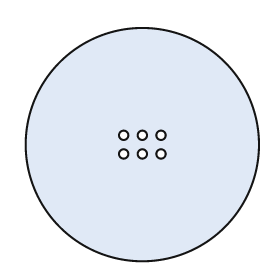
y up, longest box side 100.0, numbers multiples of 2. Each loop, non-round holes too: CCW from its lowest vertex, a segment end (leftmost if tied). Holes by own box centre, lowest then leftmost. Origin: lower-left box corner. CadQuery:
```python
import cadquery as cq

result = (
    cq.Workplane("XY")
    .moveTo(50.0, 50.0)
    .circle(50.0)
    .moveTo(42.0, 46.0)
    .circle(2.0)
    .moveTo(50.0, 46.0)
    .circle(2.0)
    .moveTo(58.0, 46.0)
    .circle(2.0)
    .moveTo(42.0, 54.0)
    .circle(2.0)
    .moveTo(50.0, 54.0)
    .circle(2.0)
    .moveTo(58.0, 54.0)
    .circle(2.0)
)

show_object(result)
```